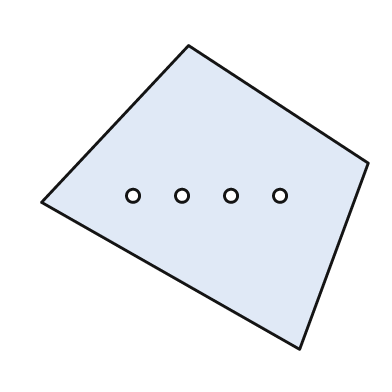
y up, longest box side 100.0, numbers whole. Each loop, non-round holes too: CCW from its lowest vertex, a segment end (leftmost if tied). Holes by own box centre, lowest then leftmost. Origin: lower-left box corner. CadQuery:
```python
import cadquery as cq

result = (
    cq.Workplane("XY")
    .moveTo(79.0, 0.0)
    .lineTo(100.0, 57.0)
    .lineTo(45.0, 93.0)
    .lineTo(0.0, 45.0)
    .close()
    .moveTo(28.0, 47.0)
    .circle(2.0)
    .moveTo(43.0, 47.0)
    .circle(2.0)
    .moveTo(58.0, 47.0)
    .circle(2.0)
    .moveTo(73.0, 47.0)
    .circle(2.0)
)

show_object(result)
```